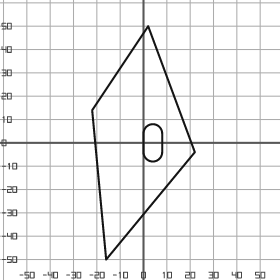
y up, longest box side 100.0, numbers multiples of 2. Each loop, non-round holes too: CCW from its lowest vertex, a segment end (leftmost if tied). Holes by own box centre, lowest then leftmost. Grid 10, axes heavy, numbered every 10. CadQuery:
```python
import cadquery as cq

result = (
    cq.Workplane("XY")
    .moveTo(-16.0, -50.0)
    .lineTo(22.0, -4.0)
    .lineTo(2.0, 50.0)
    .lineTo(-22.0, 14.0)
    .close()
    .moveTo(0.0, -4.0)
    .threePointArc((4.0, -8.0), (8.0, -4.0))
    .lineTo(8.0, 4.0)
    .threePointArc((4.0, 8.0), (0.0, 4.0))
    .close()
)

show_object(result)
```